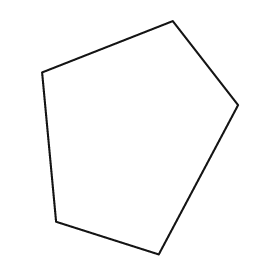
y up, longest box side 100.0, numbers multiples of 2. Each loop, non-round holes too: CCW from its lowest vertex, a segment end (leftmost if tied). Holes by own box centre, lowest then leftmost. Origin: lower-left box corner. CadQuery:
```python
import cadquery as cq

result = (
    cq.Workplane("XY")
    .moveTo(50.0, 0.0)
    .lineTo(84.0, 64.0)
    .lineTo(56.0, 100.0)
    .lineTo(0.0, 78.0)
    .lineTo(6.0, 14.0)
    .close()
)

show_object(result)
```